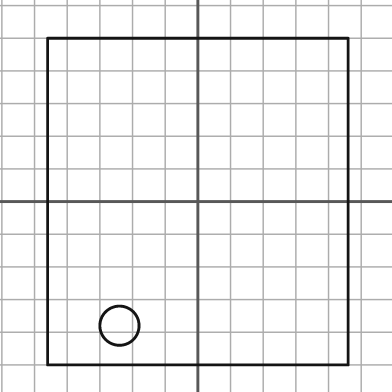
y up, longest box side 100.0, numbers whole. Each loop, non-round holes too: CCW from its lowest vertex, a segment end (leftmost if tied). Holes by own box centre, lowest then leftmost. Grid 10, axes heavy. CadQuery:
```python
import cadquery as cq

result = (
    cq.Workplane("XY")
    .moveTo(-46.0, -50.0)
    .lineTo(46.0, -50.0)
    .lineTo(46.0, 50.0)
    .lineTo(-46.0, 50.0)
    .close()
    .moveTo(-24.0, -38.0)
    .circle(6.0)
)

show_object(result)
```